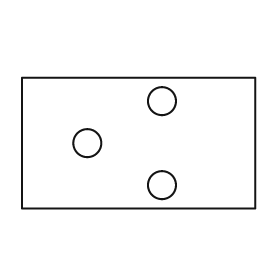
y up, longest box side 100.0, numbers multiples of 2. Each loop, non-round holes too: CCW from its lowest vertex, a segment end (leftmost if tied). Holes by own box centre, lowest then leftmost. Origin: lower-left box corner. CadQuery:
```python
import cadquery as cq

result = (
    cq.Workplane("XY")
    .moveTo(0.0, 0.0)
    .lineTo(100.0, 0.0)
    .lineTo(100.0, 56.0)
    .lineTo(0.0, 56.0)
    .close()
    .moveTo(60.0, 10.0)
    .circle(6.0)
    .moveTo(28.0, 28.0)
    .circle(6.0)
    .moveTo(60.0, 46.0)
    .circle(6.0)
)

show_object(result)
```